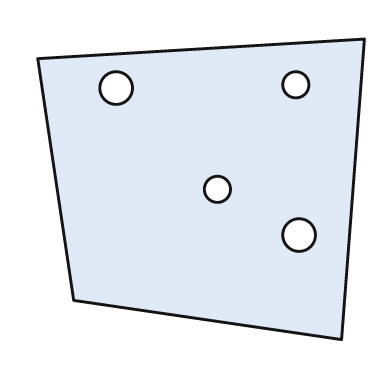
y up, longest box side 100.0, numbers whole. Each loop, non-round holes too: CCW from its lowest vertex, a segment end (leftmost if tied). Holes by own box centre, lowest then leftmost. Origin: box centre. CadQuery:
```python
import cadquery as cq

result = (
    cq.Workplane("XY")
    .moveTo(43.0, -46.0)
    .lineTo(50.0, 46.0)
    .lineTo(-50.0, 40.0)
    .lineTo(-39.0, -34.0)
    .close()
    .moveTo(30.0, -14.0)
    .circle(5.0)
    .moveTo(5.0, 0.0)
    .circle(4.0)
    .moveTo(-26.0, 31.0)
    .circle(5.0)
    .moveTo(29.0, 32.0)
    .circle(4.0)
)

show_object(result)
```